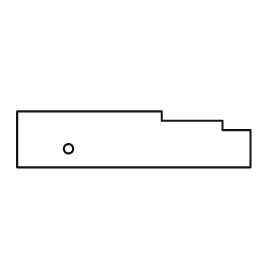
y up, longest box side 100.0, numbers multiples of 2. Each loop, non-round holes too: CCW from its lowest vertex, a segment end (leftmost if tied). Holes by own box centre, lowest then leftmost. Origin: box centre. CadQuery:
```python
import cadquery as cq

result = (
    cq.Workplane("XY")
    .moveTo(-50.0, -12.0)
    .lineTo(50.0, -12.0)
    .lineTo(50.0, 4.0)
    .lineTo(38.0, 4.0)
    .lineTo(38.0, 8.0)
    .lineTo(12.0, 8.0)
    .lineTo(12.0, 12.0)
    .lineTo(-50.0, 12.0)
    .close()
    .moveTo(-28.0, -4.0)
    .circle(2.0)
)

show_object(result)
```